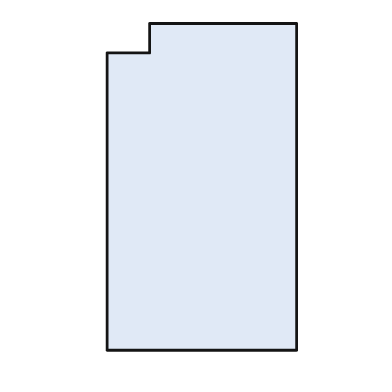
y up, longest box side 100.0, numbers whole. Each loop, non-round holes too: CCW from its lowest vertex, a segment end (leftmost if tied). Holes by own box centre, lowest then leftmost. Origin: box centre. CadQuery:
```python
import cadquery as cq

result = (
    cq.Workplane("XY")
    .moveTo(-29.0, -50.0)
    .lineTo(29.0, -50.0)
    .lineTo(29.0, 50.0)
    .lineTo(-16.0, 50.0)
    .lineTo(-16.0, 41.0)
    .lineTo(-29.0, 41.0)
    .close()
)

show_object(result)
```